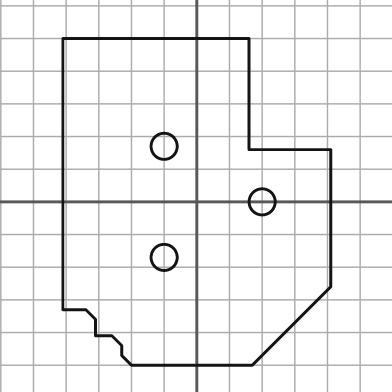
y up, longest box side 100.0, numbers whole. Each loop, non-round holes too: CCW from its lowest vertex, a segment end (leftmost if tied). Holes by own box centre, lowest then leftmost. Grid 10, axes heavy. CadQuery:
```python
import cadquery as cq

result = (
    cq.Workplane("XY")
    .moveTo(-20.0, -50.0)
    .lineTo(17.0, -50.0)
    .lineTo(41.0, -26.0)
    .lineTo(41.0, 16.0)
    .lineTo(16.0, 16.0)
    .lineTo(16.0, 50.0)
    .lineTo(-41.0, 50.0)
    .lineTo(-41.0, -33.0)
    .lineTo(-34.0, -33.0)
    .lineTo(-31.0, -36.0)
    .lineTo(-31.0, -41.0)
    .lineTo(-26.0, -41.0)
    .lineTo(-23.0, -44.0)
    .lineTo(-23.0, -47.0)
    .close()
    .moveTo(-10.0, -17.0)
    .circle(4.0)
    .moveTo(20.0, 0.0)
    .circle(4.0)
    .moveTo(-10.0, 17.0)
    .circle(4.0)
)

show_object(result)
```